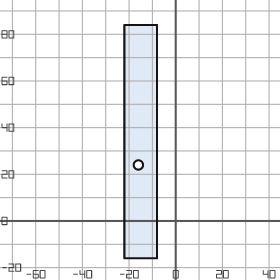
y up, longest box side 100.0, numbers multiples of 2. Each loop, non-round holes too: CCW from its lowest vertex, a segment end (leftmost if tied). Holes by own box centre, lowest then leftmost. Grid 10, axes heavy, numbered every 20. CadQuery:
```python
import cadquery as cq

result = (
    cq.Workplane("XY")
    .moveTo(-22.0, -16.0)
    .lineTo(-8.0, -16.0)
    .lineTo(-8.0, 84.0)
    .lineTo(-22.0, 84.0)
    .close()
    .moveTo(-16.0, 24.0)
    .circle(2.0)
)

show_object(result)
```